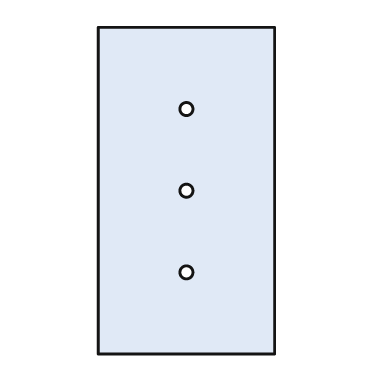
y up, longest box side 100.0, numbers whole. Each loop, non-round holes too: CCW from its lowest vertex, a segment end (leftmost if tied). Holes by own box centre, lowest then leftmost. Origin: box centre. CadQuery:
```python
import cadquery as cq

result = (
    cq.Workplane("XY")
    .moveTo(-27.0, -50.0)
    .lineTo(27.0, -50.0)
    .lineTo(27.0, 50.0)
    .lineTo(-27.0, 50.0)
    .close()
    .moveTo(0.0, -25.0)
    .circle(2.0)
    .moveTo(0.0, 0.0)
    .circle(2.0)
    .moveTo(0.0, 25.0)
    .circle(2.0)
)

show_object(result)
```